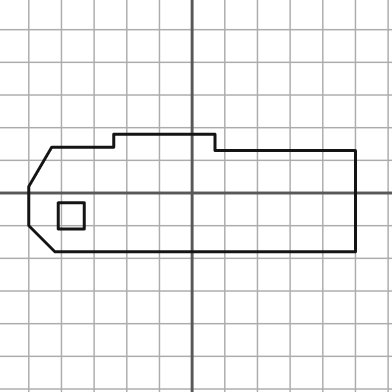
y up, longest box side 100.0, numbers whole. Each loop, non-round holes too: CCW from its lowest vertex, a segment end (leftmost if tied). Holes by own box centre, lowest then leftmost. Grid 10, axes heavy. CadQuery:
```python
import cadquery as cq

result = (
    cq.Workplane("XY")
    .moveTo(-42.0, -18.0)
    .lineTo(50.0, -18.0)
    .lineTo(50.0, 13.0)
    .lineTo(7.0, 13.0)
    .lineTo(7.0, 18.0)
    .lineTo(-24.0, 18.0)
    .lineTo(-24.0, 14.0)
    .lineTo(-43.0, 14.0)
    .lineTo(-50.0, 2.0)
    .lineTo(-50.0, -10.0)
    .close()
    .moveTo(-41.0, -11.0)
    .lineTo(-33.0, -11.0)
    .lineTo(-33.0, -3.0)
    .lineTo(-41.0, -3.0)
    .close()
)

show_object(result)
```